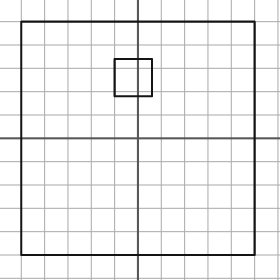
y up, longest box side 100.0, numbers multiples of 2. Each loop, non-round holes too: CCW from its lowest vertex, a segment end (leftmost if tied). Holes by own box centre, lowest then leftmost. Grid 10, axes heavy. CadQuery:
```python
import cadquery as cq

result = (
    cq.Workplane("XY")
    .moveTo(-50.0, -50.0)
    .lineTo(50.0, -50.0)
    .lineTo(50.0, 50.0)
    .lineTo(-50.0, 50.0)
    .close()
    .moveTo(-10.0, 18.0)
    .lineTo(6.0, 18.0)
    .lineTo(6.0, 34.0)
    .lineTo(-10.0, 34.0)
    .close()
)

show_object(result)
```